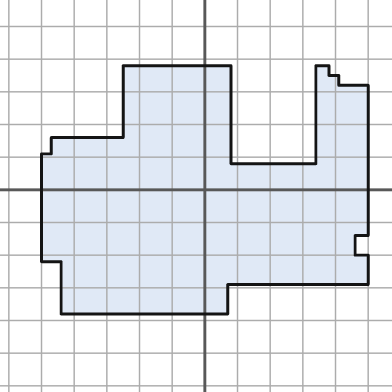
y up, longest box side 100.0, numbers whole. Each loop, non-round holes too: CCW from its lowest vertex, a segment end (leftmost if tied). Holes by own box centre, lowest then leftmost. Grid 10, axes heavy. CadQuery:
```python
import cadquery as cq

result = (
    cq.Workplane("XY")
    .moveTo(-44.0, -38.0)
    .lineTo(7.0, -38.0)
    .lineTo(7.0, -29.0)
    .lineTo(50.0, -29.0)
    .lineTo(50.0, -20.0)
    .lineTo(46.0, -20.0)
    .lineTo(46.0, -14.0)
    .lineTo(50.0, -14.0)
    .lineTo(50.0, 32.0)
    .lineTo(41.0, 32.0)
    .lineTo(41.0, 35.0)
    .lineTo(38.0, 35.0)
    .lineTo(38.0, 38.0)
    .lineTo(34.0, 38.0)
    .lineTo(34.0, 8.0)
    .lineTo(8.0, 8.0)
    .lineTo(8.0, 38.0)
    .lineTo(-25.0, 38.0)
    .lineTo(-25.0, 16.0)
    .lineTo(-47.0, 16.0)
    .lineTo(-47.0, 11.0)
    .lineTo(-50.0, 11.0)
    .lineTo(-50.0, -22.0)
    .lineTo(-44.0, -22.0)
    .close()
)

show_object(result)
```